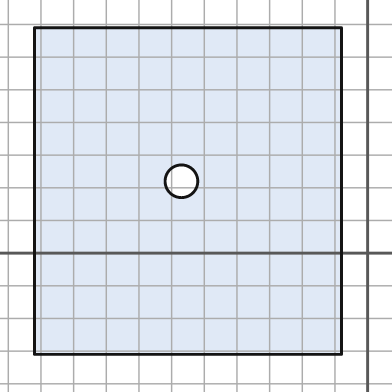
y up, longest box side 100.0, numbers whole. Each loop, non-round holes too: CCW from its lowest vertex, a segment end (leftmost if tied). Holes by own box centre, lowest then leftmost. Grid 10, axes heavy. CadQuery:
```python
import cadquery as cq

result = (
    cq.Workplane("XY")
    .moveTo(-102.0, -31.0)
    .lineTo(-8.0, -31.0)
    .lineTo(-8.0, 69.0)
    .lineTo(-102.0, 69.0)
    .close()
    .moveTo(-57.0, 22.0)
    .circle(5.0)
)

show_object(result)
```